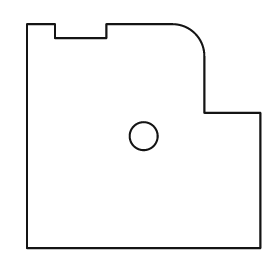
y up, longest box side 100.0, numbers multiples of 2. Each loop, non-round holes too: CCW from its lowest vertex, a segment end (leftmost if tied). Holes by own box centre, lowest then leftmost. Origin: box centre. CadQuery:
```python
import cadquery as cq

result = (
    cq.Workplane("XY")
    .moveTo(-50.0, -48.0)
    .lineTo(50.0, -48.0)
    .lineTo(50.0, 10.0)
    .lineTo(26.0, 10.0)
    .lineTo(26.0, 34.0)
    .threePointArc((22.0, 44.0), (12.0, 48.0))
    .lineTo(-16.0, 48.0)
    .lineTo(-16.0, 42.0)
    .lineTo(-38.0, 42.0)
    .lineTo(-38.0, 48.0)
    .lineTo(-50.0, 48.0)
    .close()
    .moveTo(0.0, 0.0)
    .circle(6.0)
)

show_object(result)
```